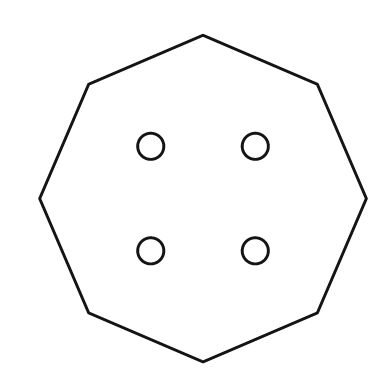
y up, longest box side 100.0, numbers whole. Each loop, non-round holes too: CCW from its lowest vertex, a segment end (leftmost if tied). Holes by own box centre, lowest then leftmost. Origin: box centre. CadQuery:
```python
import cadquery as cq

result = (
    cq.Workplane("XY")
    .moveTo(0.0, -50.0)
    .lineTo(35.0, -35.0)
    .lineTo(50.0, 0.0)
    .lineTo(35.0, 35.0)
    .lineTo(0.0, 50.0)
    .lineTo(-35.0, 35.0)
    .lineTo(-50.0, 0.0)
    .lineTo(-35.0, -35.0)
    .close()
    .moveTo(-16.0, -16.0)
    .circle(4.0)
    .moveTo(16.0, -16.0)
    .circle(4.0)
    .moveTo(-16.0, 16.0)
    .circle(4.0)
    .moveTo(16.0, 16.0)
    .circle(4.0)
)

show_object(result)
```